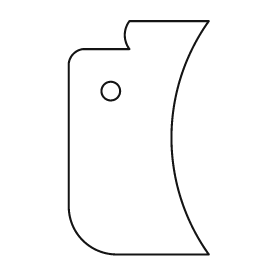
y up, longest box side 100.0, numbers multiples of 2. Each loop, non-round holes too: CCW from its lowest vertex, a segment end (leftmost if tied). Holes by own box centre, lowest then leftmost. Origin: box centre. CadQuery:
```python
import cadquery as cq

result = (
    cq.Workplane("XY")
    .moveTo(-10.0, -50.0)
    .lineTo(30.0, -50.0)
    .threePointArc((14.0, 0.0), (30.0, 50.0))
    .lineTo(-4.0, 50.0)
    .threePointArc((-6.0, 44.0), (-4.0, 38.0))
    .lineTo(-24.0, 38.0)
    .threePointArc((-28.0, 36.0), (-30.0, 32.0))
    .lineTo(-30.0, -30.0)
    .threePointArc((-24.0, -44.0), (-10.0, -50.0))
    .close()
    .moveTo(-12.0, 20.0)
    .circle(4.0)
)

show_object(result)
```